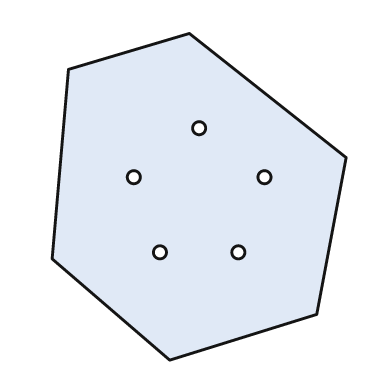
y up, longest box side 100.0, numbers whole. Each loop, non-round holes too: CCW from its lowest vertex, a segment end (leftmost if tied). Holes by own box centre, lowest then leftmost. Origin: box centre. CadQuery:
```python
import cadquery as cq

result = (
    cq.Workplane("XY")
    .moveTo(-9.0, -50.0)
    .lineTo(36.0, -36.0)
    .lineTo(45.0, 12.0)
    .lineTo(-3.0, 50.0)
    .lineTo(-40.0, 39.0)
    .lineTo(-45.0, -19.0)
    .close()
    .moveTo(-12.0, -17.0)
    .circle(2.0)
    .moveTo(12.0, -17.0)
    .circle(2.0)
    .moveTo(-20.0, 6.0)
    .circle(2.0)
    .moveTo(20.0, 6.0)
    .circle(2.0)
    .moveTo(0.0, 21.0)
    .circle(2.0)
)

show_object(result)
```